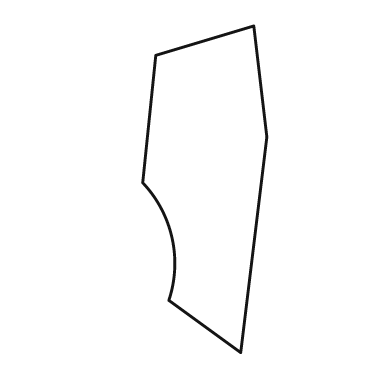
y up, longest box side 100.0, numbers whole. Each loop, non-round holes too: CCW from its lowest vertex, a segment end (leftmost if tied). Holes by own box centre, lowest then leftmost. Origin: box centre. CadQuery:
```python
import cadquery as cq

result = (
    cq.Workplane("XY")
    .moveTo(11.0, -50.0)
    .lineTo(19.0, 16.0)
    .lineTo(15.0, 50.0)
    .lineTo(-15.0, 41.0)
    .lineTo(-19.0, 2.0)
    .threePointArc((-10.0, -15.0), (-11.0, -34.0))
    .close()
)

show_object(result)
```